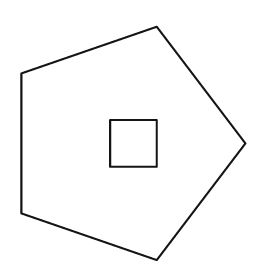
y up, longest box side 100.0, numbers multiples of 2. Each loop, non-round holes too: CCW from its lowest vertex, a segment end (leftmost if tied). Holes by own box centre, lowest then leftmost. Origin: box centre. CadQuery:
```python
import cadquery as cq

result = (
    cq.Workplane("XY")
    .moveTo(10.0, -50.0)
    .lineTo(48.0, 0.0)
    .lineTo(10.0, 50.0)
    .lineTo(-48.0, 30.0)
    .lineTo(-48.0, -30.0)
    .close()
    .moveTo(-10.0, -10.0)
    .lineTo(10.0, -10.0)
    .lineTo(10.0, 10.0)
    .lineTo(-10.0, 10.0)
    .close()
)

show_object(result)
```